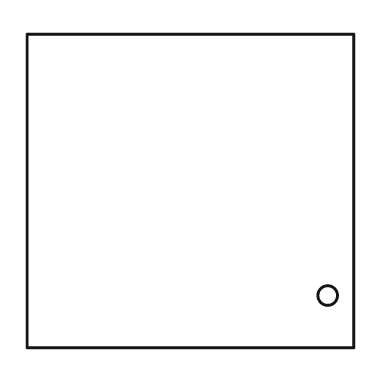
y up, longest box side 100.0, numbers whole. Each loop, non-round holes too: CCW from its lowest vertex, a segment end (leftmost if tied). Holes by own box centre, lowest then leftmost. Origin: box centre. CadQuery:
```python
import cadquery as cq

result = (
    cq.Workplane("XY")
    .moveTo(-50.0, -48.0)
    .lineTo(50.0, -48.0)
    .lineTo(50.0, 48.0)
    .lineTo(-50.0, 48.0)
    .close()
    .moveTo(42.0, -32.0)
    .circle(3.0)
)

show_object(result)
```